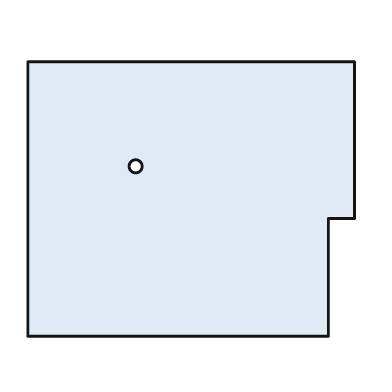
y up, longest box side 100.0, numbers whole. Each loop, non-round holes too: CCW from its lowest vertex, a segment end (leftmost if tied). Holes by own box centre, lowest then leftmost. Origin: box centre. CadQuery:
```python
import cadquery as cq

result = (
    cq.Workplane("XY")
    .moveTo(-50.0, -42.0)
    .lineTo(42.0, -42.0)
    .lineTo(42.0, -6.0)
    .lineTo(50.0, -6.0)
    .lineTo(50.0, 42.0)
    .lineTo(-50.0, 42.0)
    .close()
    .moveTo(-17.0, 10.0)
    .circle(2.0)
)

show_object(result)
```